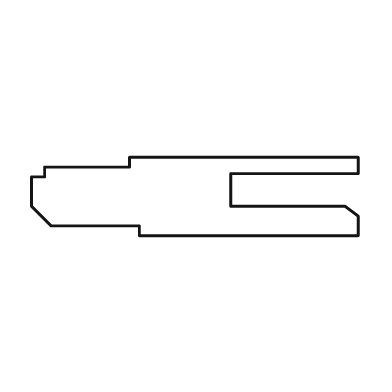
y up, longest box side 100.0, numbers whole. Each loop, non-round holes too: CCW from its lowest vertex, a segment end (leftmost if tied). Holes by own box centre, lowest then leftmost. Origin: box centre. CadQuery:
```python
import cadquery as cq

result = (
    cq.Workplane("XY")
    .moveTo(-17.0, -12.0)
    .lineTo(50.0, -12.0)
    .lineTo(50.0, -6.0)
    .lineTo(46.0, -3.0)
    .lineTo(11.0, -3.0)
    .lineTo(11.0, 7.0)
    .lineTo(50.0, 7.0)
    .lineTo(50.0, 12.0)
    .lineTo(-20.0, 12.0)
    .lineTo(-20.0, 9.0)
    .lineTo(-46.0, 9.0)
    .lineTo(-46.0, 6.0)
    .lineTo(-50.0, 6.0)
    .lineTo(-50.0, -3.0)
    .lineTo(-44.0, -9.0)
    .lineTo(-17.0, -9.0)
    .close()
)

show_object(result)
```